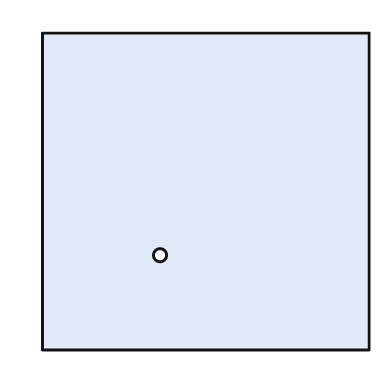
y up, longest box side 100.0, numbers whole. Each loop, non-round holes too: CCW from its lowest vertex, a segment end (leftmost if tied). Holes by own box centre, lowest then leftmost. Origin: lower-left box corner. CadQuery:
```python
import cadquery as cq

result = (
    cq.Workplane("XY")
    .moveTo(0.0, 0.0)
    .lineTo(100.0, 0.0)
    .lineTo(100.0, 97.0)
    .lineTo(0.0, 97.0)
    .close()
    .moveTo(36.0, 29.0)
    .circle(2.0)
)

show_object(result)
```